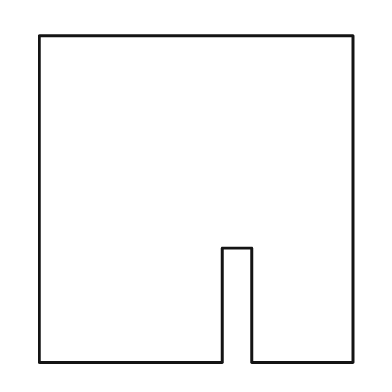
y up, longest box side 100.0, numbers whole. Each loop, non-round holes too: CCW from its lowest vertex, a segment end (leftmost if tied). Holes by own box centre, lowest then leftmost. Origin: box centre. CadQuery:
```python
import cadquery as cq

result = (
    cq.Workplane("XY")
    .moveTo(-48.0, -50.0)
    .lineTo(8.0, -50.0)
    .lineTo(8.0, -15.0)
    .lineTo(17.0, -15.0)
    .lineTo(17.0, -50.0)
    .lineTo(48.0, -50.0)
    .lineTo(48.0, 50.0)
    .lineTo(-48.0, 50.0)
    .close()
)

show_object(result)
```